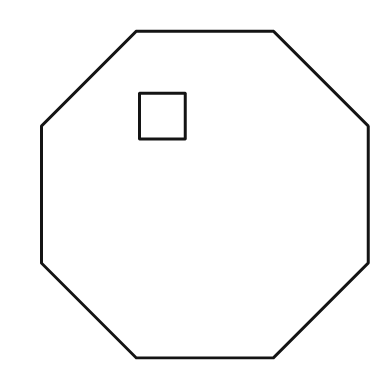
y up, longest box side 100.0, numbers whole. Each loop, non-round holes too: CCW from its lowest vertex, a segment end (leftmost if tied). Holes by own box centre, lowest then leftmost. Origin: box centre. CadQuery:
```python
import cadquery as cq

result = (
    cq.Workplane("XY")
    .moveTo(-21.0, -50.0)
    .lineTo(21.0, -50.0)
    .lineTo(50.0, -21.0)
    .lineTo(50.0, 21.0)
    .lineTo(21.0, 50.0)
    .lineTo(-21.0, 50.0)
    .lineTo(-50.0, 21.0)
    .lineTo(-50.0, -21.0)
    .close()
    .moveTo(-20.0, 17.0)
    .lineTo(-6.0, 17.0)
    .lineTo(-6.0, 31.0)
    .lineTo(-20.0, 31.0)
    .close()
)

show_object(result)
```